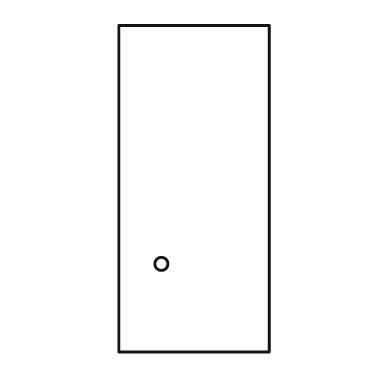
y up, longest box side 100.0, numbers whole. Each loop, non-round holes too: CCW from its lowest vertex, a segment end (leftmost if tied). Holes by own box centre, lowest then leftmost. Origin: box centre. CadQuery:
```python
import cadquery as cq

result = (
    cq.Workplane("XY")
    .moveTo(-23.0, -50.0)
    .lineTo(23.0, -50.0)
    .lineTo(23.0, 50.0)
    .lineTo(-23.0, 50.0)
    .close()
    .moveTo(-10.0, -23.0)
    .circle(2.0)
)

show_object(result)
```